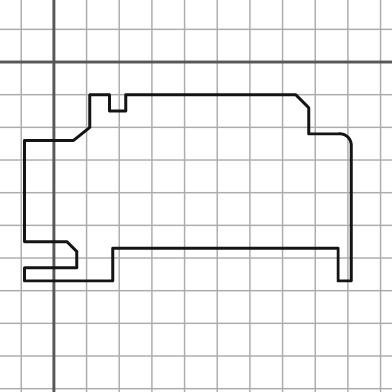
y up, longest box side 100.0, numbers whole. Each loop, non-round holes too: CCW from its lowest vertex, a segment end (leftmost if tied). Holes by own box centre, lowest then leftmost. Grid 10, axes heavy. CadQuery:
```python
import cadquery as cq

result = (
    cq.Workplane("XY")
    .moveTo(-9.0, -67.0)
    .lineTo(18.0, -67.0)
    .lineTo(18.0, -57.0)
    .lineTo(87.0, -57.0)
    .lineTo(87.0, -67.0)
    .lineTo(91.0, -67.0)
    .lineTo(91.0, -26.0)
    .threePointArc((90.0, -23.0), (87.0, -22.0))
    .lineTo(78.0, -22.0)
    .lineTo(78.0, -14.0)
    .lineTo(74.0, -10.0)
    .lineTo(22.0, -10.0)
    .lineTo(22.0, -15.0)
    .lineTo(17.0, -15.0)
    .lineTo(17.0, -10.0)
    .lineTo(11.0, -10.0)
    .lineTo(11.0, -20.0)
    .lineTo(6.0, -24.0)
    .lineTo(-9.0, -24.0)
    .lineTo(-9.0, -55.0)
    .lineTo(4.0, -55.0)
    .lineTo(7.0, -58.0)
    .lineTo(7.0, -63.0)
    .lineTo(-9.0, -63.0)
    .close()
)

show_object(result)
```